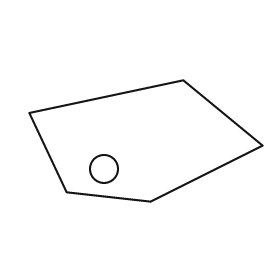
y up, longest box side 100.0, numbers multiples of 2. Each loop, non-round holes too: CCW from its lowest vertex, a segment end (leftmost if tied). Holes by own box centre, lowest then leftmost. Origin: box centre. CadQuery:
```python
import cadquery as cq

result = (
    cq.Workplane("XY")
    .moveTo(2.0, -26.0)
    .lineTo(50.0, -2.0)
    .lineTo(16.0, 26.0)
    .lineTo(-50.0, 12.0)
    .lineTo(-34.0, -22.0)
    .close()
    .moveTo(-18.0, -12.0)
    .circle(6.0)
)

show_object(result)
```